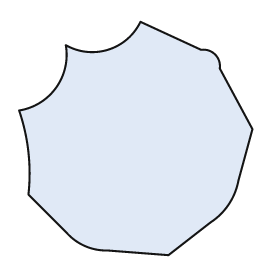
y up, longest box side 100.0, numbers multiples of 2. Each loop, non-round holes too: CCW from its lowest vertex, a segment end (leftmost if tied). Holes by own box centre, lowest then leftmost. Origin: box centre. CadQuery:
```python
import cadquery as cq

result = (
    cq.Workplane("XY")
    .moveTo(14.0, -50.0)
    .lineTo(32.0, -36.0)
    .threePointArc((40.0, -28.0), (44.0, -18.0))
    .lineTo(50.0, 4.0)
    .lineTo(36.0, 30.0)
    .threePointArc((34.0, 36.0), (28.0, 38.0))
    .lineTo(2.0, 50.0)
    .threePointArc((-12.0, 38.0), (-30.0, 40.0))
    .threePointArc((-34.0, 22.0), (-50.0, 12.0))
    .threePointArc((-46.0, -6.0), (-46.0, -24.0))
    .lineTo(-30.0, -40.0)
    .threePointArc((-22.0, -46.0), (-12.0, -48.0))
    .close()
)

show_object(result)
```